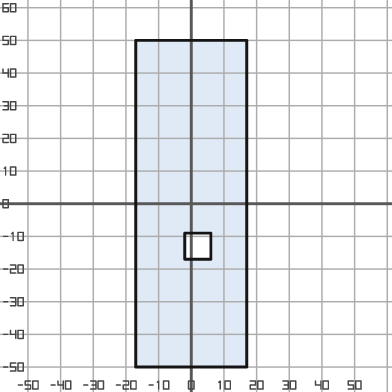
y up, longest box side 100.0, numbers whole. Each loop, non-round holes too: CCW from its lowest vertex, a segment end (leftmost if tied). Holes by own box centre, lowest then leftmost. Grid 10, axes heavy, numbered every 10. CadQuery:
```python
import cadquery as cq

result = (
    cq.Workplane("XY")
    .moveTo(-17.0, -50.0)
    .lineTo(17.0, -50.0)
    .lineTo(17.0, 50.0)
    .lineTo(-17.0, 50.0)
    .close()
    .moveTo(-2.0, -17.0)
    .lineTo(6.0, -17.0)
    .lineTo(6.0, -9.0)
    .lineTo(-2.0, -9.0)
    .close()
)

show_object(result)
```